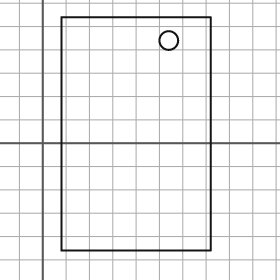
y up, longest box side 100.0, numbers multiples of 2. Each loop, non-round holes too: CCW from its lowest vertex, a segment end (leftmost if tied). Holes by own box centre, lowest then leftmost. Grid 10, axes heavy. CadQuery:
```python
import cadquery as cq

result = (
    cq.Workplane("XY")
    .moveTo(8.0, -46.0)
    .lineTo(72.0, -46.0)
    .lineTo(72.0, 54.0)
    .lineTo(8.0, 54.0)
    .close()
    .moveTo(54.0, 44.0)
    .circle(4.0)
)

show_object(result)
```